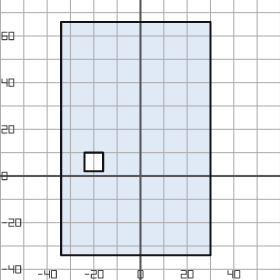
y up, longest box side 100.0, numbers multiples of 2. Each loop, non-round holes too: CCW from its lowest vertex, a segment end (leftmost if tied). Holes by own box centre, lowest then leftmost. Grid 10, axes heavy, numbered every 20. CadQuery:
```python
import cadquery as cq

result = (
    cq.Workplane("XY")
    .moveTo(-34.0, -34.0)
    .lineTo(30.0, -34.0)
    .lineTo(30.0, 66.0)
    .lineTo(-34.0, 66.0)
    .close()
    .moveTo(-24.0, 2.0)
    .lineTo(-16.0, 2.0)
    .lineTo(-16.0, 10.0)
    .lineTo(-24.0, 10.0)
    .close()
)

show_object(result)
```